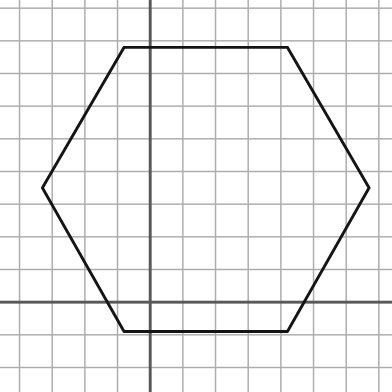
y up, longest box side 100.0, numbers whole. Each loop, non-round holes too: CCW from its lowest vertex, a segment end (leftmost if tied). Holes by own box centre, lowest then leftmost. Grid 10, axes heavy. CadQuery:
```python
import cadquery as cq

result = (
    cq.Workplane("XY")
    .moveTo(-8.0, -9.0)
    .lineTo(42.0, -9.0)
    .lineTo(67.0, 35.0)
    .lineTo(42.0, 78.0)
    .lineTo(-8.0, 78.0)
    .lineTo(-33.0, 35.0)
    .close()
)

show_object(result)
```